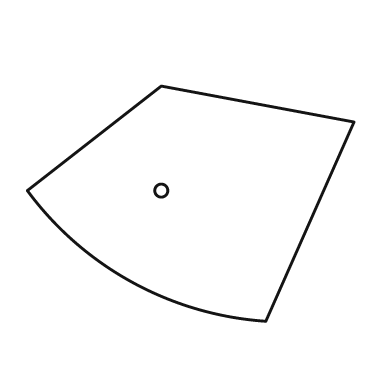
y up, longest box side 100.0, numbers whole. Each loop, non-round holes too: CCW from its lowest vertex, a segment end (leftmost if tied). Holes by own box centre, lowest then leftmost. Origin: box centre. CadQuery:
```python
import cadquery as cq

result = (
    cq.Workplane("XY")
    .moveTo(23.0, -36.0)
    .lineTo(50.0, 25.0)
    .lineTo(-9.0, 36.0)
    .lineTo(-50.0, 4.0)
    .threePointArc((-18.0, -24.0), (23.0, -36.0))
    .close()
    .moveTo(-9.0, 4.0)
    .circle(2.0)
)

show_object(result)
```